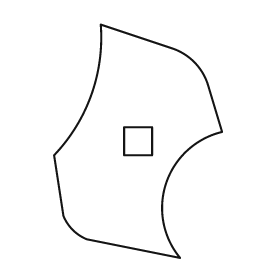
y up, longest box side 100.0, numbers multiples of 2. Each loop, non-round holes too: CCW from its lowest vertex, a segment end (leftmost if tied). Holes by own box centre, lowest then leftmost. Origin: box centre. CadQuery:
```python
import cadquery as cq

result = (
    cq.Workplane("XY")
    .moveTo(18.0, -50.0)
    .threePointArc((12.0, -18.0), (36.0, 4.0))
    .lineTo(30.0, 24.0)
    .threePointArc((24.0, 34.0), (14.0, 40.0))
    .lineTo(-16.0, 50.0)
    .threePointArc((-20.0, 20.0), (-36.0, -6.0))
    .lineTo(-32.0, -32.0)
    .threePointArc((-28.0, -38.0), (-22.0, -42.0))
    .close()
    .moveTo(-6.0, -6.0)
    .lineTo(6.0, -6.0)
    .lineTo(6.0, 6.0)
    .lineTo(-6.0, 6.0)
    .close()
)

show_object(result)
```